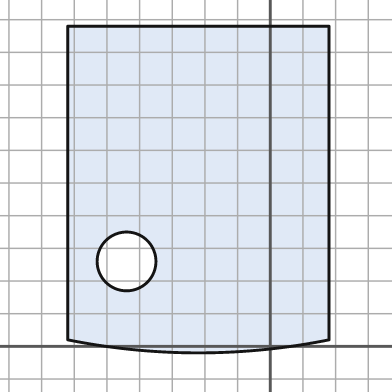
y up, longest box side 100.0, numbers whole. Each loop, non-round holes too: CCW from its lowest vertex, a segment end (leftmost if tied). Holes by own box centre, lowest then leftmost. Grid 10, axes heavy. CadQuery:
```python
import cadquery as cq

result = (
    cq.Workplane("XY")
    .moveTo(-62.0, 2.0)
    .threePointArc((-22.0, -2.0), (18.0, 2.0))
    .lineTo(18.0, 98.0)
    .lineTo(-62.0, 98.0)
    .close()
    .moveTo(-44.0, 26.0)
    .circle(9.0)
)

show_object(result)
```